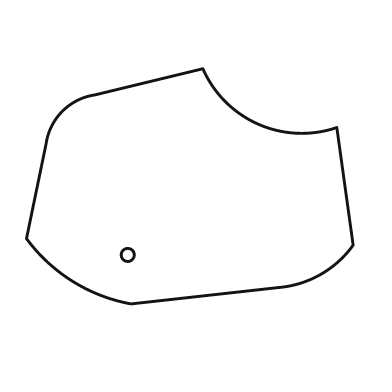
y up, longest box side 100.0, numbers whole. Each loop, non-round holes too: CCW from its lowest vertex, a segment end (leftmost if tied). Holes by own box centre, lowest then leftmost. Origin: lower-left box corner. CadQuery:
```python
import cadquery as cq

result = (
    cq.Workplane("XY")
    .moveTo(32.0, 0.0)
    .lineTo(77.0, 5.0)
    .threePointArc((90.0, 9.0), (100.0, 18.0))
    .lineTo(95.0, 54.0)
    .threePointArc((71.0, 55.0), (54.0, 72.0))
    .lineTo(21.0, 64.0)
    .threePointArc((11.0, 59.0), (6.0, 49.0))
    .lineTo(0.0, 20.0)
    .threePointArc((14.0, 7.0), (32.0, 0.0))
    .close()
    .moveTo(31.0, 15.0)
    .circle(2.0)
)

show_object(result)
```